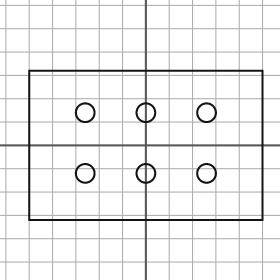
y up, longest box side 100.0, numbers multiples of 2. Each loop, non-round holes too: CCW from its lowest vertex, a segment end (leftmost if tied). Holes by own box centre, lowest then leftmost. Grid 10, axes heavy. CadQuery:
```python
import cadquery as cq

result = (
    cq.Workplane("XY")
    .moveTo(-50.0, -32.0)
    .lineTo(50.0, -32.0)
    .lineTo(50.0, 32.0)
    .lineTo(-50.0, 32.0)
    .close()
    .moveTo(-26.0, -12.0)
    .circle(4.0)
    .moveTo(0.0, -12.0)
    .circle(4.0)
    .moveTo(26.0, -12.0)
    .circle(4.0)
    .moveTo(-26.0, 14.0)
    .circle(4.0)
    .moveTo(0.0, 14.0)
    .circle(4.0)
    .moveTo(26.0, 14.0)
    .circle(4.0)
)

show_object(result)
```